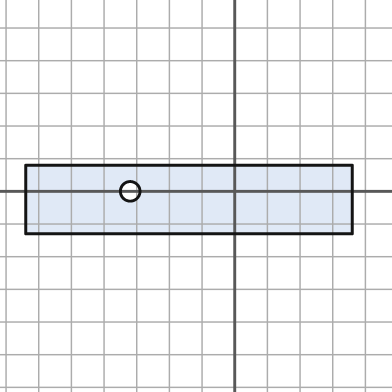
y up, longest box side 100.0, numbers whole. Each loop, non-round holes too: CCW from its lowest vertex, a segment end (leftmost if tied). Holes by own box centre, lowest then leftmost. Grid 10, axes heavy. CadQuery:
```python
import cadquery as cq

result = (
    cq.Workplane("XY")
    .moveTo(-64.0, -13.0)
    .lineTo(36.0, -13.0)
    .lineTo(36.0, 8.0)
    .lineTo(-64.0, 8.0)
    .close()
    .moveTo(-32.0, 0.0)
    .circle(3.0)
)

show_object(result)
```